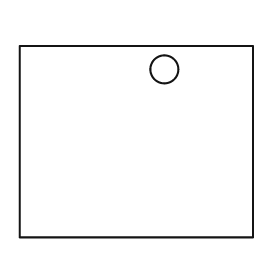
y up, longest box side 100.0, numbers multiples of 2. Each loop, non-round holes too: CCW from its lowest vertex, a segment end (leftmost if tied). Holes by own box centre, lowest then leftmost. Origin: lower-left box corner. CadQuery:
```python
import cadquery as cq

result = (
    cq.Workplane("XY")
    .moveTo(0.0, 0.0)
    .lineTo(100.0, 0.0)
    .lineTo(100.0, 82.0)
    .lineTo(0.0, 82.0)
    .close()
    .moveTo(62.0, 72.0)
    .circle(6.0)
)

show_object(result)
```